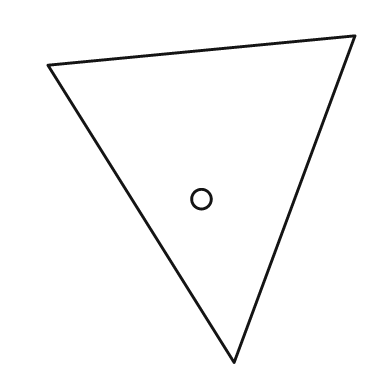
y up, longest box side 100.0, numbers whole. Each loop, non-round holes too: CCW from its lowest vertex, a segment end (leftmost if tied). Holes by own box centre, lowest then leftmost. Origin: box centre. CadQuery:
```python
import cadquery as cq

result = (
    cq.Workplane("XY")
    .moveTo(10.0, -50.0)
    .lineTo(47.0, 50.0)
    .lineTo(-47.0, 41.0)
    .close()
    .moveTo(0.0, 0.0)
    .circle(3.0)
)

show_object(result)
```